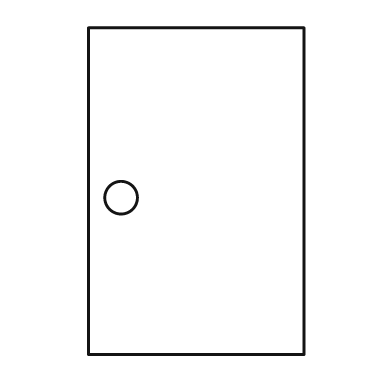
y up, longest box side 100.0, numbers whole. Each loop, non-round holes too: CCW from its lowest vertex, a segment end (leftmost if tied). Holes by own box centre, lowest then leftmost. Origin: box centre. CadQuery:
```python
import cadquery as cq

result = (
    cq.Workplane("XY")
    .moveTo(-33.0, -50.0)
    .lineTo(33.0, -50.0)
    .lineTo(33.0, 50.0)
    .lineTo(-33.0, 50.0)
    .close()
    .moveTo(-23.0, -2.0)
    .circle(5.0)
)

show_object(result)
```